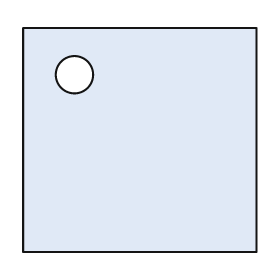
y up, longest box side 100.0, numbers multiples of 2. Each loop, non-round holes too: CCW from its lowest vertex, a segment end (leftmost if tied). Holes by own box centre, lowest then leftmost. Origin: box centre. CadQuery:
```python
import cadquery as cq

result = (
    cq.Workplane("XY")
    .moveTo(-50.0, -48.0)
    .lineTo(50.0, -48.0)
    .lineTo(50.0, 48.0)
    .lineTo(-50.0, 48.0)
    .close()
    .moveTo(-28.0, 28.0)
    .circle(8.0)
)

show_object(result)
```